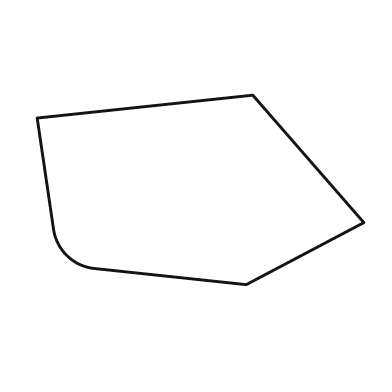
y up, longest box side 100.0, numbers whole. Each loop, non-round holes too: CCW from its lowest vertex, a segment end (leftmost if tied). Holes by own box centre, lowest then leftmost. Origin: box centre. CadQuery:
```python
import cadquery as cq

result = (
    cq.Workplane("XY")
    .moveTo(14.0, -29.0)
    .lineTo(50.0, -10.0)
    .lineTo(16.0, 29.0)
    .lineTo(-50.0, 22.0)
    .lineTo(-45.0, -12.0)
    .threePointArc((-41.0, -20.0), (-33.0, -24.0))
    .close()
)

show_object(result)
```